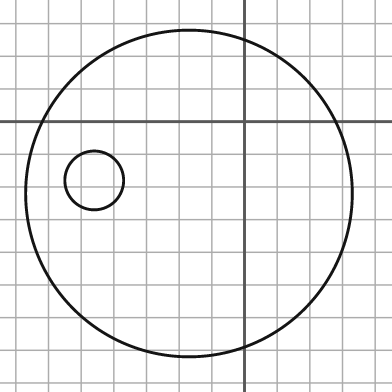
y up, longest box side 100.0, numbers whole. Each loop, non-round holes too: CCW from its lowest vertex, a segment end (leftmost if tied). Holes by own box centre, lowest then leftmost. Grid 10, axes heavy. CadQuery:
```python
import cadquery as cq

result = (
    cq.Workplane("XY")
    .moveTo(-17.0, -22.0)
    .circle(50.0)
    .moveTo(-46.0, -18.0)
    .circle(9.0)
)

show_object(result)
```